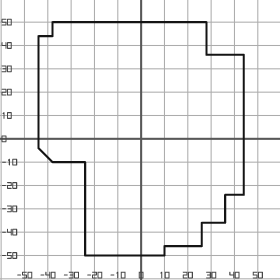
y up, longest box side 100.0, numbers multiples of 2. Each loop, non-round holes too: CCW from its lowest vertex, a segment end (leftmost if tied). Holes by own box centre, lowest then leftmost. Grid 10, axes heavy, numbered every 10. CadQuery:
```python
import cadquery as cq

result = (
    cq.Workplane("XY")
    .moveTo(-24.0, -50.0)
    .lineTo(10.0, -50.0)
    .lineTo(10.0, -46.0)
    .lineTo(26.0, -46.0)
    .lineTo(26.0, -36.0)
    .lineTo(36.0, -36.0)
    .lineTo(36.0, -24.0)
    .lineTo(44.0, -24.0)
    .lineTo(44.0, 36.0)
    .lineTo(28.0, 36.0)
    .lineTo(28.0, 50.0)
    .lineTo(-38.0, 50.0)
    .lineTo(-38.0, 44.0)
    .lineTo(-44.0, 44.0)
    .lineTo(-44.0, -4.0)
    .lineTo(-38.0, -10.0)
    .lineTo(-24.0, -10.0)
    .close()
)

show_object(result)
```